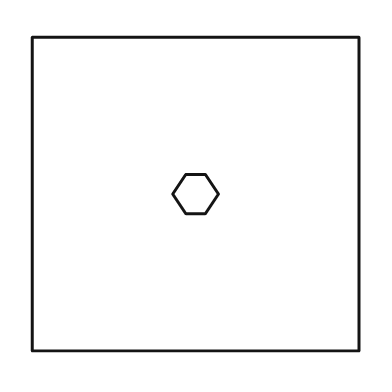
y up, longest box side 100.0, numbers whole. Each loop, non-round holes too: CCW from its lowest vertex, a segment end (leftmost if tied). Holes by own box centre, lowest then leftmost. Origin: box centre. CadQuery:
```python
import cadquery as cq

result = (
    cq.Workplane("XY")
    .moveTo(-50.0, -48.0)
    .lineTo(50.0, -48.0)
    .lineTo(50.0, 48.0)
    .lineTo(-50.0, 48.0)
    .close()
    .moveTo(-3.0, -6.0)
    .lineTo(3.0, -6.0)
    .lineTo(7.0, 0.0)
    .lineTo(3.0, 6.0)
    .lineTo(-3.0, 6.0)
    .lineTo(-7.0, 0.0)
    .close()
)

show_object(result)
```